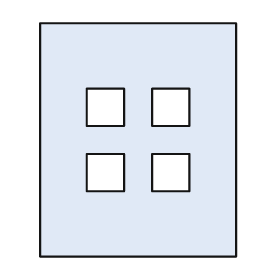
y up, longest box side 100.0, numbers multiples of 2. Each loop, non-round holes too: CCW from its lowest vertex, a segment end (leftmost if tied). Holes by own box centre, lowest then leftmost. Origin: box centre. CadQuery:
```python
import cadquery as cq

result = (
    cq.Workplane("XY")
    .moveTo(-42.0, -50.0)
    .lineTo(42.0, -50.0)
    .lineTo(42.0, 50.0)
    .lineTo(-42.0, 50.0)
    .close()
    .moveTo(-22.0, -22.0)
    .lineTo(-6.0, -22.0)
    .lineTo(-6.0, -6.0)
    .lineTo(-22.0, -6.0)
    .close()
    .moveTo(6.0, -22.0)
    .lineTo(22.0, -22.0)
    .lineTo(22.0, -6.0)
    .lineTo(6.0, -6.0)
    .close()
    .moveTo(-22.0, 6.0)
    .lineTo(-6.0, 6.0)
    .lineTo(-6.0, 22.0)
    .lineTo(-22.0, 22.0)
    .close()
    .moveTo(6.0, 6.0)
    .lineTo(22.0, 6.0)
    .lineTo(22.0, 22.0)
    .lineTo(6.0, 22.0)
    .close()
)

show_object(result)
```